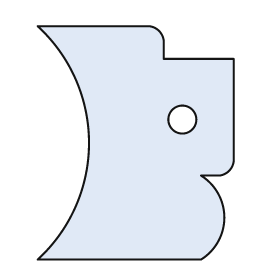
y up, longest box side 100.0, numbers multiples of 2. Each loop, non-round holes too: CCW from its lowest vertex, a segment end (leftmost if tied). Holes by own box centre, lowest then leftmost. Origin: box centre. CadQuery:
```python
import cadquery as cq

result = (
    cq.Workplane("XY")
    .moveTo(-42.0, -50.0)
    .lineTo(28.0, -50.0)
    .threePointArc((38.0, -32.0), (28.0, -14.0))
    .lineTo(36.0, -14.0)
    .threePointArc((40.0, -12.0), (42.0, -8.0))
    .lineTo(42.0, 36.0)
    .lineTo(12.0, 36.0)
    .lineTo(12.0, 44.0)
    .threePointArc((10.0, 48.0), (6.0, 50.0))
    .lineTo(-42.0, 50.0)
    .threePointArc((-20.0, 0.0), (-42.0, -50.0))
    .close()
    .moveTo(20.0, 10.0)
    .circle(6.0)
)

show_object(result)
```